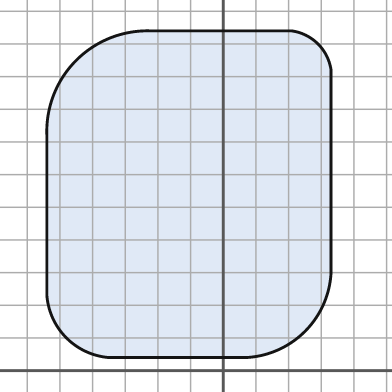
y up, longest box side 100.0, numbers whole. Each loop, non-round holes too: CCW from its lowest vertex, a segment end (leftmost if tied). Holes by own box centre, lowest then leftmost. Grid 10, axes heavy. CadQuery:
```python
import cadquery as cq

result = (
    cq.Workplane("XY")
    .moveTo(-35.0, 4.0)
    .lineTo(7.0, 4.0)
    .threePointArc((25.0, 12.0), (33.0, 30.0))
    .lineTo(33.0, 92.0)
    .threePointArc((29.0, 100.0), (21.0, 104.0))
    .lineTo(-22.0, 104.0)
    .threePointArc((-45.0, 95.0), (-54.0, 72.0))
    .lineTo(-54.0, 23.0)
    .threePointArc((-48.0, 10.0), (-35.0, 4.0))
    .close()
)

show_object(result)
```